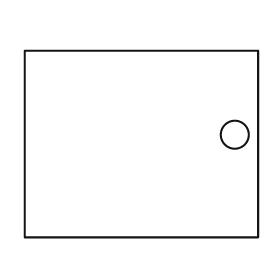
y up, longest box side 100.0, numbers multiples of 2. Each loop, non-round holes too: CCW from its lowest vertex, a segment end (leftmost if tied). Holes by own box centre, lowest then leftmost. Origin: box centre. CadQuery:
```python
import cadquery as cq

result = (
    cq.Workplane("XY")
    .moveTo(-50.0, -40.0)
    .lineTo(50.0, -40.0)
    .lineTo(50.0, 40.0)
    .lineTo(-50.0, 40.0)
    .close()
    .moveTo(40.0, 4.0)
    .circle(6.0)
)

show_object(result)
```